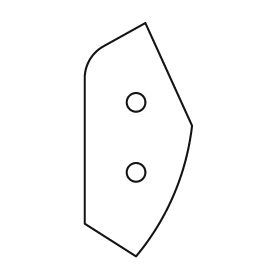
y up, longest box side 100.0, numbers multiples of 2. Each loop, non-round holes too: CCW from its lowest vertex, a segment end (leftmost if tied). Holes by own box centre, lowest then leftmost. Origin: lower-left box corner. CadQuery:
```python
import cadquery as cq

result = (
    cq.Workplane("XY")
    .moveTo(22.0, 0.0)
    .threePointArc((38.0, 26.0), (46.0, 56.0))
    .lineTo(26.0, 100.0)
    .lineTo(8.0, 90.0)
    .threePointArc((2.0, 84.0), (0.0, 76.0))
    .lineTo(0.0, 14.0)
    .close()
    .moveTo(22.0, 36.0)
    .circle(4.0)
    .moveTo(22.0, 66.0)
    .circle(4.0)
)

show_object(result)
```